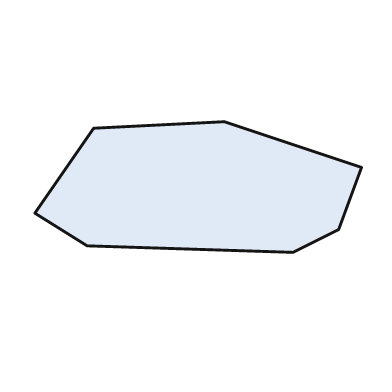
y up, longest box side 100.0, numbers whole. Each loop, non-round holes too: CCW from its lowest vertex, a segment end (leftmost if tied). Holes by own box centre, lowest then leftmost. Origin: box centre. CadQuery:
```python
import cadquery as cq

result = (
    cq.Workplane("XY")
    .moveTo(29.0, -20.0)
    .lineTo(43.0, -13.0)
    .lineTo(50.0, 6.0)
    .lineTo(8.0, 20.0)
    .lineTo(-32.0, 18.0)
    .lineTo(-50.0, -8.0)
    .lineTo(-34.0, -18.0)
    .close()
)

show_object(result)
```